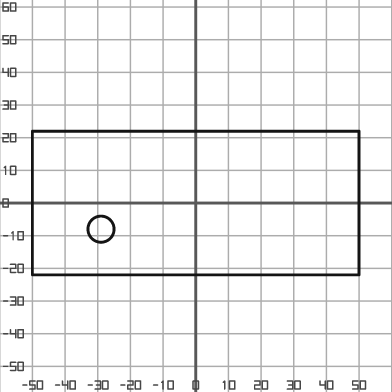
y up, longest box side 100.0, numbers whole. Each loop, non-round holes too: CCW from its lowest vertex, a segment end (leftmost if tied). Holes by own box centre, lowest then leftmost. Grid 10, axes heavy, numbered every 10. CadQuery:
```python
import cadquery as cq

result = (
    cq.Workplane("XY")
    .moveTo(-50.0, -22.0)
    .lineTo(50.0, -22.0)
    .lineTo(50.0, 22.0)
    .lineTo(-50.0, 22.0)
    .close()
    .moveTo(-29.0, -8.0)
    .circle(4.0)
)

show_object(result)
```